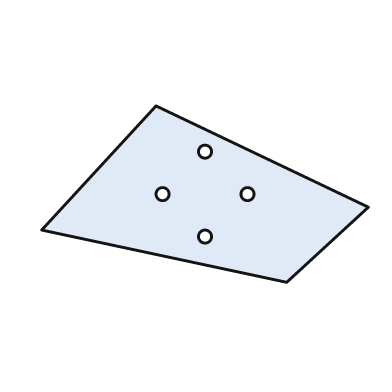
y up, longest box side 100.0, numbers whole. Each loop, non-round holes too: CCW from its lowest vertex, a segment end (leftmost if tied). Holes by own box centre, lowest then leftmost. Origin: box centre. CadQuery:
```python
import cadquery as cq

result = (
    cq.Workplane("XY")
    .moveTo(25.0, -27.0)
    .lineTo(50.0, -4.0)
    .lineTo(-15.0, 27.0)
    .lineTo(-50.0, -11.0)
    .close()
    .moveTo(0.0, -13.0)
    .circle(2.0)
    .moveTo(-13.0, 0.0)
    .circle(2.0)
    .moveTo(13.0, 0.0)
    .circle(2.0)
    .moveTo(0.0, 13.0)
    .circle(2.0)
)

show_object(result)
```